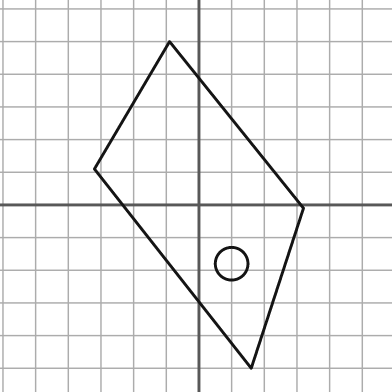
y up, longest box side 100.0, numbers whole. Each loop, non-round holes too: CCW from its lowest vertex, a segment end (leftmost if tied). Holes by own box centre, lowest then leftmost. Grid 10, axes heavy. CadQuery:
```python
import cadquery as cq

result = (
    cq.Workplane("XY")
    .moveTo(16.0, -50.0)
    .lineTo(32.0, -1.0)
    .lineTo(-9.0, 50.0)
    .lineTo(-32.0, 11.0)
    .close()
    .moveTo(10.0, -18.0)
    .circle(5.0)
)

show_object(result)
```